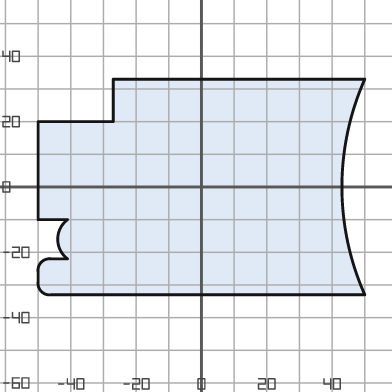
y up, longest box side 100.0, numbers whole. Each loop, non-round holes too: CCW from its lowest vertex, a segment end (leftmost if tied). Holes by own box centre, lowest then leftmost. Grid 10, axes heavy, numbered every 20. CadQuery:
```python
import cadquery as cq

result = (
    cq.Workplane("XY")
    .moveTo(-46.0, -33.0)
    .lineTo(50.0, -33.0)
    .threePointArc((43.0, 0.0), (50.0, 33.0))
    .lineTo(-27.0, 33.0)
    .lineTo(-27.0, 20.0)
    .lineTo(-50.0, 20.0)
    .lineTo(-50.0, -10.0)
    .lineTo(-41.0, -10.0)
    .threePointArc((-44.0, -16.0), (-41.0, -22.0))
    .lineTo(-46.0, -22.0)
    .threePointArc((-49.0, -23.0), (-50.0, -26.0))
    .lineTo(-50.0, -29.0)
    .threePointArc((-49.0, -32.0), (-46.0, -33.0))
    .close()
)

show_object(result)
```